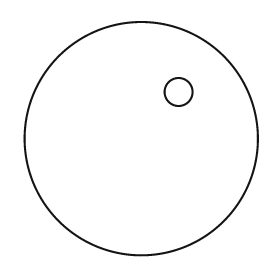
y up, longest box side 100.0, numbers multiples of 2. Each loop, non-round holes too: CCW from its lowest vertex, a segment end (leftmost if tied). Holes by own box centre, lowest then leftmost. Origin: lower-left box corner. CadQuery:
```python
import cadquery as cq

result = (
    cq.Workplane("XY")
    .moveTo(50.0, 50.0)
    .circle(50.0)
    .moveTo(66.0, 70.0)
    .circle(6.0)
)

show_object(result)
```